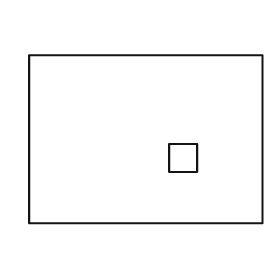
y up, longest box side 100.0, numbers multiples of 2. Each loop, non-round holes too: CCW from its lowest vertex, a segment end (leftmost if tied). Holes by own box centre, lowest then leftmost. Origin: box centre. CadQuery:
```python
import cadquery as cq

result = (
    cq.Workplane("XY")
    .moveTo(-50.0, -36.0)
    .lineTo(50.0, -36.0)
    .lineTo(50.0, 36.0)
    .lineTo(-50.0, 36.0)
    .close()
    .moveTo(10.0, -14.0)
    .lineTo(22.0, -14.0)
    .lineTo(22.0, -2.0)
    .lineTo(10.0, -2.0)
    .close()
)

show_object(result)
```